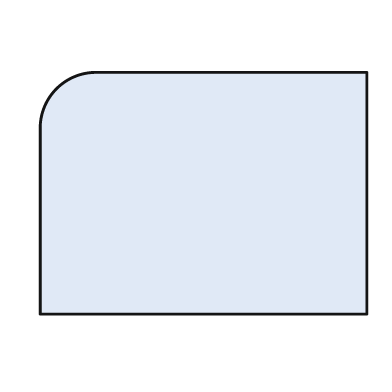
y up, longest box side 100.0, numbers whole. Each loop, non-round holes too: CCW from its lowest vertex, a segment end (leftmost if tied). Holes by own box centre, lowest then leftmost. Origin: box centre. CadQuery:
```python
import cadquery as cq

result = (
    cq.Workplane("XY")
    .moveTo(-50.0, -37.0)
    .lineTo(50.0, -37.0)
    .lineTo(50.0, 37.0)
    .lineTo(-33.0, 37.0)
    .threePointArc((-45.0, 32.0), (-50.0, 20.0))
    .close()
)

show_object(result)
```